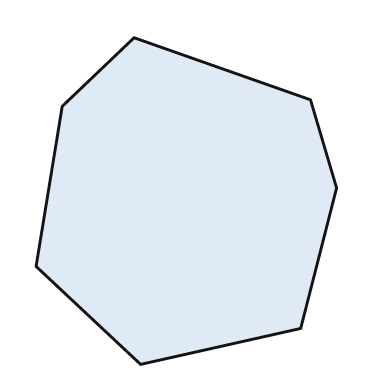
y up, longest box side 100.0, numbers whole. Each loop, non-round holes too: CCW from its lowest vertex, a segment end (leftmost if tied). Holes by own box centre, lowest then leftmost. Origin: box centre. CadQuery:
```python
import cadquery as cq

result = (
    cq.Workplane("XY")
    .moveTo(-14.0, -50.0)
    .lineTo(35.0, -39.0)
    .lineTo(46.0, 4.0)
    .lineTo(38.0, 31.0)
    .lineTo(-16.0, 50.0)
    .lineTo(-38.0, 29.0)
    .lineTo(-46.0, -20.0)
    .close()
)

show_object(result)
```